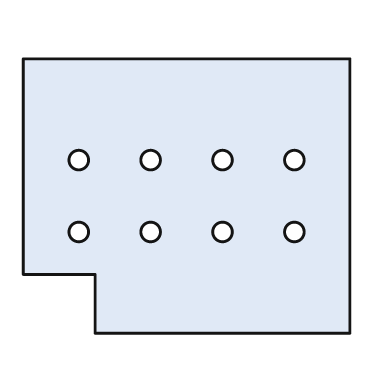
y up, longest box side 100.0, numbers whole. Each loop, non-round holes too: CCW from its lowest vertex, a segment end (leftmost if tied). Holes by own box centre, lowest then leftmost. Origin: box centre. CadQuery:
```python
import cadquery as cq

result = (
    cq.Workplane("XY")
    .moveTo(-28.0, -42.0)
    .lineTo(50.0, -42.0)
    .lineTo(50.0, 42.0)
    .lineTo(-50.0, 42.0)
    .lineTo(-50.0, -24.0)
    .lineTo(-28.0, -24.0)
    .close()
    .moveTo(-33.0, -11.0)
    .circle(3.0)
    .moveTo(-11.0, -11.0)
    .circle(3.0)
    .moveTo(11.0, -11.0)
    .circle(3.0)
    .moveTo(33.0, -11.0)
    .circle(3.0)
    .moveTo(-33.0, 11.0)
    .circle(3.0)
    .moveTo(-11.0, 11.0)
    .circle(3.0)
    .moveTo(11.0, 11.0)
    .circle(3.0)
    .moveTo(33.0, 11.0)
    .circle(3.0)
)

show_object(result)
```